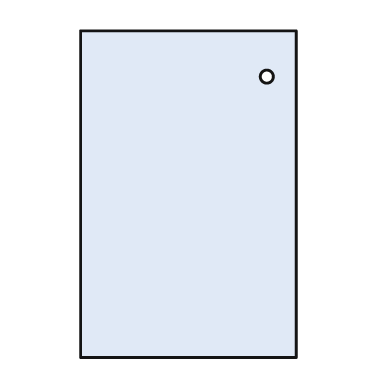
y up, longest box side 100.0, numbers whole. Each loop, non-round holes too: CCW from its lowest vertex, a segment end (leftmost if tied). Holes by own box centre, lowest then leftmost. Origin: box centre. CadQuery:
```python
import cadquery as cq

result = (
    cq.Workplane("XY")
    .moveTo(-33.0, -50.0)
    .lineTo(33.0, -50.0)
    .lineTo(33.0, 50.0)
    .lineTo(-33.0, 50.0)
    .close()
    .moveTo(24.0, 36.0)
    .circle(2.0)
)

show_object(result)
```